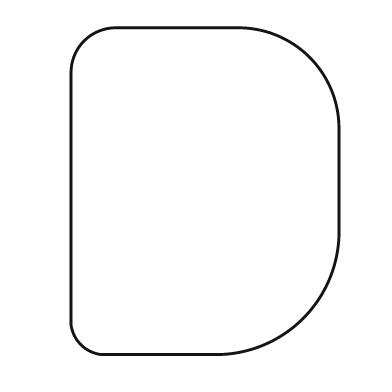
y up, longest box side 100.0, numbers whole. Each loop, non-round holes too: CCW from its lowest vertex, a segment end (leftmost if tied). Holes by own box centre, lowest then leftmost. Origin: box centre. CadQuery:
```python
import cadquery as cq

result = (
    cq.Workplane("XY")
    .moveTo(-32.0, -50.0)
    .lineTo(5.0, -50.0)
    .threePointArc((30.0, -39.0), (41.0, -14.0))
    .lineTo(41.0, 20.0)
    .threePointArc((32.0, 41.0), (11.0, 50.0))
    .lineTo(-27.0, 50.0)
    .threePointArc((-37.0, 46.0), (-41.0, 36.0))
    .lineTo(-41.0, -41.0)
    .threePointArc((-38.0, -47.0), (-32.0, -50.0))
    .close()
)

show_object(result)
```